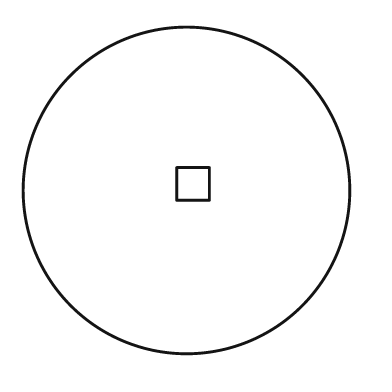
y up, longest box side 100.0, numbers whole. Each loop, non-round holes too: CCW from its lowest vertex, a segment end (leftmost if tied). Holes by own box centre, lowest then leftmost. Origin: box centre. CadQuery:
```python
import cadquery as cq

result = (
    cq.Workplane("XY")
    .moveTo(0.0, 0.0)
    .circle(50.0)
    .moveTo(-3.0, -3.0)
    .lineTo(7.0, -3.0)
    .lineTo(7.0, 7.0)
    .lineTo(-3.0, 7.0)
    .close()
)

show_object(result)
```